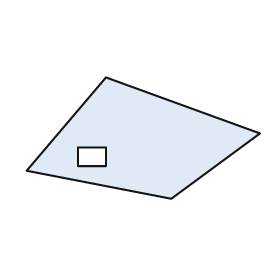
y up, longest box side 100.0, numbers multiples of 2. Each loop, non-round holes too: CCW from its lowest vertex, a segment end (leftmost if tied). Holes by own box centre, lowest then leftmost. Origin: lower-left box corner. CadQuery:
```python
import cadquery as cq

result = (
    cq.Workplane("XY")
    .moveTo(62.0, 0.0)
    .lineTo(100.0, 28.0)
    .lineTo(34.0, 52.0)
    .lineTo(0.0, 12.0)
    .close()
    .moveTo(22.0, 14.0)
    .lineTo(34.0, 14.0)
    .lineTo(34.0, 22.0)
    .lineTo(22.0, 22.0)
    .close()
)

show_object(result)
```